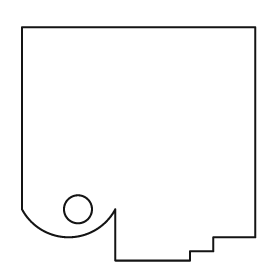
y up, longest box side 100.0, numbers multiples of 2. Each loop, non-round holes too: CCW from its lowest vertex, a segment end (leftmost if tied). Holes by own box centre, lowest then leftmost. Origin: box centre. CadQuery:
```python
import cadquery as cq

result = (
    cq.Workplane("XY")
    .moveTo(-10.0, -50.0)
    .lineTo(22.0, -50.0)
    .lineTo(22.0, -46.0)
    .lineTo(32.0, -46.0)
    .lineTo(32.0, -40.0)
    .lineTo(50.0, -40.0)
    .lineTo(50.0, 50.0)
    .lineTo(-50.0, 50.0)
    .lineTo(-50.0, -28.0)
    .threePointArc((-30.0, -40.0), (-10.0, -28.0))
    .close()
    .moveTo(-26.0, -28.0)
    .circle(6.0)
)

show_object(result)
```